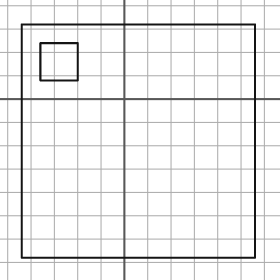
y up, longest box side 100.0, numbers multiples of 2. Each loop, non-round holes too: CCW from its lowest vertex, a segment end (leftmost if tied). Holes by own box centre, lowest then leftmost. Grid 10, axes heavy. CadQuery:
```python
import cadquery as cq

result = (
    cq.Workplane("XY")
    .moveTo(-44.0, -68.0)
    .lineTo(56.0, -68.0)
    .lineTo(56.0, 32.0)
    .lineTo(-44.0, 32.0)
    .close()
    .moveTo(-36.0, 8.0)
    .lineTo(-20.0, 8.0)
    .lineTo(-20.0, 24.0)
    .lineTo(-36.0, 24.0)
    .close()
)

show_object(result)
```